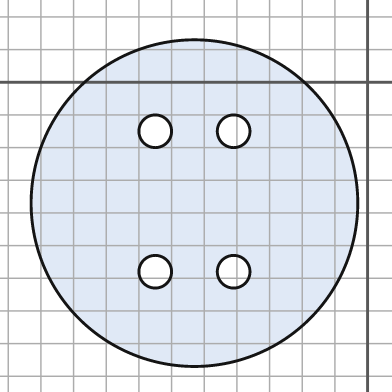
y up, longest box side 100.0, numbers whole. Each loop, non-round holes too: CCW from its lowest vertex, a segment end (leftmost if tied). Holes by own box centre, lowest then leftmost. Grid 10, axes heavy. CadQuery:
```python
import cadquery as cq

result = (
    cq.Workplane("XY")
    .moveTo(-53.0, -37.0)
    .circle(50.0)
    .moveTo(-65.0, -58.0)
    .circle(5.0)
    .moveTo(-41.0, -58.0)
    .circle(5.0)
    .moveTo(-65.0, -15.0)
    .circle(5.0)
    .moveTo(-41.0, -15.0)
    .circle(5.0)
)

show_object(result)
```